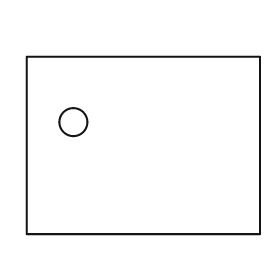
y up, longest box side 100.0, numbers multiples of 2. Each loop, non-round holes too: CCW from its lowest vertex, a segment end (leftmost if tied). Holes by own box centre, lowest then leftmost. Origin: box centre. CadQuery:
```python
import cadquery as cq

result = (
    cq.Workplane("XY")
    .moveTo(-50.0, -38.0)
    .lineTo(50.0, -38.0)
    .lineTo(50.0, 38.0)
    .lineTo(-50.0, 38.0)
    .close()
    .moveTo(-30.0, 10.0)
    .circle(6.0)
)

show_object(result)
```